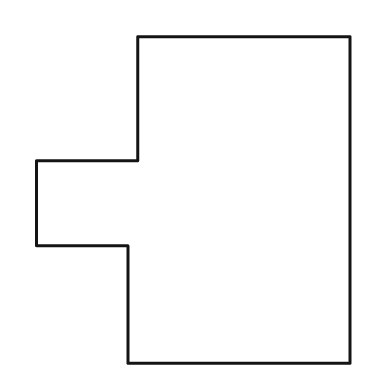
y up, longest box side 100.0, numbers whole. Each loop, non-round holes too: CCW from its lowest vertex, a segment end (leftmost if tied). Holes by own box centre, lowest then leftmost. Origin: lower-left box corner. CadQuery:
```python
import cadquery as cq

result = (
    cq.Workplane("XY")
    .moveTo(28.0, 0.0)
    .lineTo(96.0, 0.0)
    .lineTo(96.0, 100.0)
    .lineTo(31.0, 100.0)
    .lineTo(31.0, 62.0)
    .lineTo(0.0, 62.0)
    .lineTo(0.0, 36.0)
    .lineTo(28.0, 36.0)
    .close()
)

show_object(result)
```